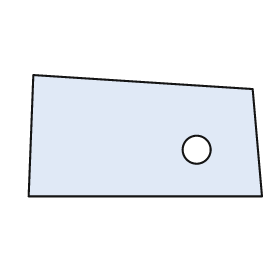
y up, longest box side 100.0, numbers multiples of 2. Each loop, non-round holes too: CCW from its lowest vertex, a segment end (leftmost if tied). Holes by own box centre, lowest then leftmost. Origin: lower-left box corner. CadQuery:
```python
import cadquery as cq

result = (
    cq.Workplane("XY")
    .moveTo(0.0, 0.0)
    .lineTo(100.0, 0.0)
    .lineTo(96.0, 46.0)
    .lineTo(2.0, 52.0)
    .close()
    .moveTo(72.0, 20.0)
    .circle(6.0)
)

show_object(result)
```